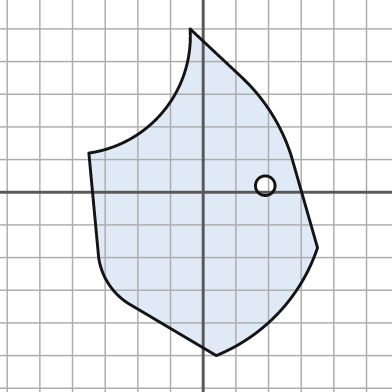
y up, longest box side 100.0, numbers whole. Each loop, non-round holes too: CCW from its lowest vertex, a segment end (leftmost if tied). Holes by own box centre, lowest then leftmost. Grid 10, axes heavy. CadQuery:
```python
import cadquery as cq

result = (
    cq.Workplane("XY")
    .moveTo(4.0, -50.0)
    .threePointArc((23.0, -37.0), (35.0, -17.0))
    .lineTo(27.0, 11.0)
    .threePointArc((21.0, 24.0), (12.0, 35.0))
    .lineTo(-4.0, 50.0)
    .threePointArc((-12.0, 25.0), (-35.0, 12.0))
    .lineTo(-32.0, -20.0)
    .threePointArc((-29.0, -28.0), (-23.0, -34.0))
    .close()
    .moveTo(19.0, 2.0)
    .circle(3.0)
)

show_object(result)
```